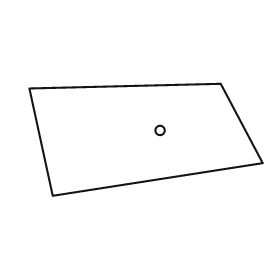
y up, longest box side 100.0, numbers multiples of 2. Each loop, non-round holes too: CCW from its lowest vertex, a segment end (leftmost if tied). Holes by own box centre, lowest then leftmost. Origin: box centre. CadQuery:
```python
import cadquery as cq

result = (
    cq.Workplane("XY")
    .moveTo(-40.0, -24.0)
    .lineTo(50.0, -10.0)
    .lineTo(32.0, 24.0)
    .lineTo(-50.0, 22.0)
    .close()
    .moveTo(6.0, 4.0)
    .circle(2.0)
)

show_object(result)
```